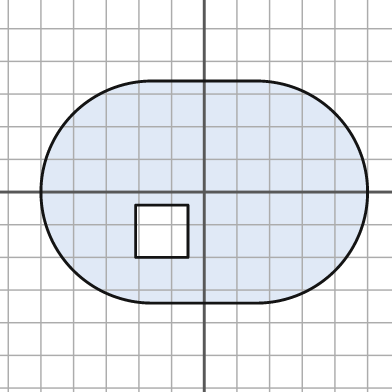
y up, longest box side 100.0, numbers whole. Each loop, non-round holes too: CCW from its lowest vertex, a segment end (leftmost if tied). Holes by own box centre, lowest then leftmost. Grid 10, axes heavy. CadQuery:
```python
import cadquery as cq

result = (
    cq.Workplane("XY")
    .moveTo(-16.0, -34.0)
    .lineTo(16.0, -34.0)
    .threePointArc((50.0, 0.0), (16.0, 34.0))
    .lineTo(-16.0, 34.0)
    .threePointArc((-50.0, 0.0), (-16.0, -34.0))
    .close()
    .moveTo(-21.0, -20.0)
    .lineTo(-5.0, -20.0)
    .lineTo(-5.0, -4.0)
    .lineTo(-21.0, -4.0)
    .close()
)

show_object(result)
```